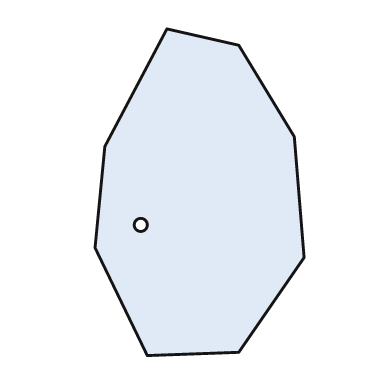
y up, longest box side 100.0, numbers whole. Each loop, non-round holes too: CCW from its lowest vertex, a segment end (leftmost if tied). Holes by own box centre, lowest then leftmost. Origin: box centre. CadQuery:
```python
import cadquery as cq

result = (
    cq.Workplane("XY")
    .moveTo(-16.0, -50.0)
    .lineTo(12.0, -49.0)
    .lineTo(32.0, -20.0)
    .lineTo(29.0, 17.0)
    .lineTo(12.0, 45.0)
    .lineTo(-10.0, 50.0)
    .lineTo(-29.0, 14.0)
    .lineTo(-32.0, -17.0)
    .close()
    .moveTo(-18.0, -10.0)
    .circle(2.0)
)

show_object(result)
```